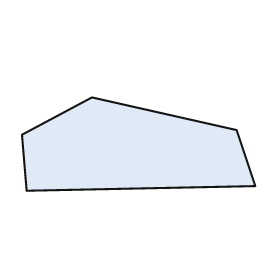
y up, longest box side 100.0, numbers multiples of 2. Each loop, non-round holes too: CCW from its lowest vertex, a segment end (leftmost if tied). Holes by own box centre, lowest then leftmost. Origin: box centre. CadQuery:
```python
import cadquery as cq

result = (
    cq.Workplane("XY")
    .moveTo(-48.0, -20.0)
    .lineTo(50.0, -18.0)
    .lineTo(42.0, 6.0)
    .lineTo(-20.0, 20.0)
    .lineTo(-50.0, 4.0)
    .close()
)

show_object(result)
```